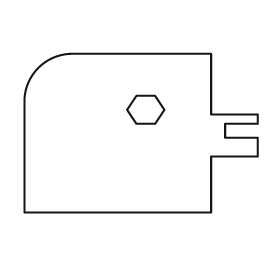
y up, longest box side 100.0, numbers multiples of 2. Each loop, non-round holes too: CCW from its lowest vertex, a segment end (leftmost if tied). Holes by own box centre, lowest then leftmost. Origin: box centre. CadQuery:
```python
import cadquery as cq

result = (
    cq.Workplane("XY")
    .moveTo(-50.0, -34.0)
    .lineTo(30.0, -34.0)
    .lineTo(30.0, -10.0)
    .lineTo(50.0, -10.0)
    .lineTo(50.0, -2.0)
    .lineTo(36.0, -2.0)
    .lineTo(36.0, 4.0)
    .lineTo(50.0, 4.0)
    .lineTo(50.0, 8.0)
    .lineTo(30.0, 8.0)
    .lineTo(30.0, 34.0)
    .lineTo(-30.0, 34.0)
    .threePointArc((-44.0, 28.0), (-50.0, 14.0))
    .close()
    .moveTo(-2.0, 4.0)
    .lineTo(6.0, 4.0)
    .lineTo(10.0, 10.0)
    .lineTo(6.0, 16.0)
    .lineTo(-2.0, 16.0)
    .lineTo(-6.0, 10.0)
    .close()
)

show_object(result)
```